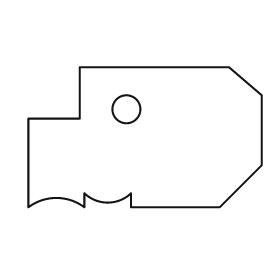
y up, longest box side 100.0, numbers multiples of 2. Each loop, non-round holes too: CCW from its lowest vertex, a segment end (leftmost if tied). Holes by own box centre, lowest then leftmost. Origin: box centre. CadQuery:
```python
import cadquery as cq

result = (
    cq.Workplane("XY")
    .moveTo(-50.0, -30.0)
    .threePointArc((-38.0, -26.0), (-26.0, -30.0))
    .lineTo(-26.0, -24.0)
    .threePointArc((-16.0, -28.0), (-6.0, -24.0))
    .lineTo(-6.0, -30.0)
    .lineTo(32.0, -30.0)
    .lineTo(50.0, -12.0)
    .lineTo(50.0, 18.0)
    .lineTo(36.0, 30.0)
    .lineTo(-28.0, 30.0)
    .lineTo(-28.0, 8.0)
    .lineTo(-50.0, 8.0)
    .close()
    .moveTo(-8.0, 12.0)
    .circle(6.0)
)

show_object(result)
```